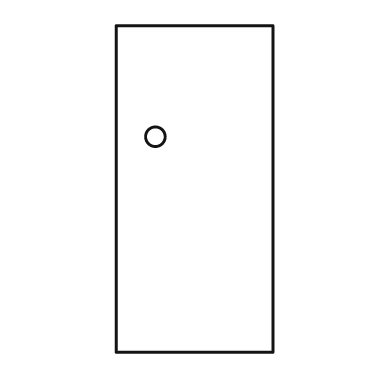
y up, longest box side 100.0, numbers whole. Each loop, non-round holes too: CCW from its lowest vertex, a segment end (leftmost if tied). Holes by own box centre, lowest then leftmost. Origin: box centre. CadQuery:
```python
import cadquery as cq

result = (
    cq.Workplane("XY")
    .moveTo(-24.0, -50.0)
    .lineTo(24.0, -50.0)
    .lineTo(24.0, 50.0)
    .lineTo(-24.0, 50.0)
    .close()
    .moveTo(-12.0, 16.0)
    .circle(3.0)
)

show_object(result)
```